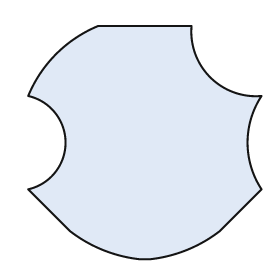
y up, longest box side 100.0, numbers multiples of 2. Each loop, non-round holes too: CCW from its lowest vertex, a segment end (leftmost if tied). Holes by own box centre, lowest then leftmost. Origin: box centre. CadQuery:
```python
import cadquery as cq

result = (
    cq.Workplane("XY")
    .moveTo(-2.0, -50.0)
    .lineTo(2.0, -50.0)
    .threePointArc((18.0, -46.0), (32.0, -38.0))
    .lineTo(50.0, -20.0)
    .threePointArc((44.0, 0.0), (50.0, 20.0))
    .threePointArc((28.0, 28.0), (20.0, 50.0))
    .lineTo(-20.0, 50.0)
    .threePointArc((-38.0, 38.0), (-50.0, 20.0))
    .threePointArc((-34.0, 0.0), (-50.0, -20.0))
    .lineTo(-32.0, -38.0)
    .threePointArc((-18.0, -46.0), (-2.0, -50.0))
    .close()
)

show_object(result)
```